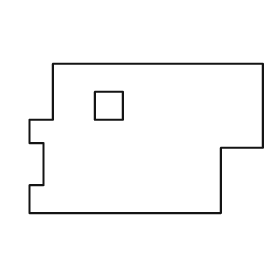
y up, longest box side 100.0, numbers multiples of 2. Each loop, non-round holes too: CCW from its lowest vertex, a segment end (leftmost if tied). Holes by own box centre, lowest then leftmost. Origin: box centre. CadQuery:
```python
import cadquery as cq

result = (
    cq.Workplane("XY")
    .moveTo(-50.0, -32.0)
    .lineTo(32.0, -32.0)
    .lineTo(32.0, -4.0)
    .lineTo(50.0, -4.0)
    .lineTo(50.0, 32.0)
    .lineTo(-40.0, 32.0)
    .lineTo(-40.0, 8.0)
    .lineTo(-50.0, 8.0)
    .lineTo(-50.0, -2.0)
    .lineTo(-44.0, -2.0)
    .lineTo(-44.0, -20.0)
    .lineTo(-50.0, -20.0)
    .close()
    .moveTo(-22.0, 8.0)
    .lineTo(-10.0, 8.0)
    .lineTo(-10.0, 20.0)
    .lineTo(-22.0, 20.0)
    .close()
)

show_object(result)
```